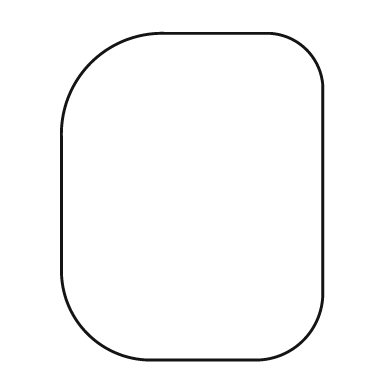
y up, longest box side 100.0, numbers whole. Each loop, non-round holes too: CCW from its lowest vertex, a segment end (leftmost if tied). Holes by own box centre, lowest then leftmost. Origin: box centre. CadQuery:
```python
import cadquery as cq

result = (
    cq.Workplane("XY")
    .moveTo(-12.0, -50.0)
    .lineTo(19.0, -50.0)
    .threePointArc((34.0, -44.0), (40.0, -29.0))
    .lineTo(40.0, 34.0)
    .threePointArc((35.0, 45.0), (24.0, 50.0))
    .lineTo(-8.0, 50.0)
    .threePointArc((-31.0, 41.0), (-40.0, 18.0))
    .lineTo(-40.0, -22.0)
    .threePointArc((-32.0, -42.0), (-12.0, -50.0))
    .close()
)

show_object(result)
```